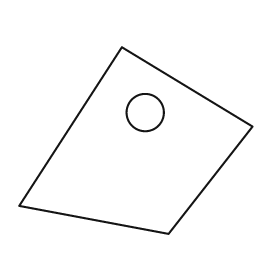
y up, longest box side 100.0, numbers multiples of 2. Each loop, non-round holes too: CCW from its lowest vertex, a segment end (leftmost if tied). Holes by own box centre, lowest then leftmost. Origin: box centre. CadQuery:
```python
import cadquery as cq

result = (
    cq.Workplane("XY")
    .moveTo(14.0, -40.0)
    .lineTo(50.0, 6.0)
    .lineTo(-6.0, 40.0)
    .lineTo(-50.0, -28.0)
    .close()
    .moveTo(4.0, 12.0)
    .circle(8.0)
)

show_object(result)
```